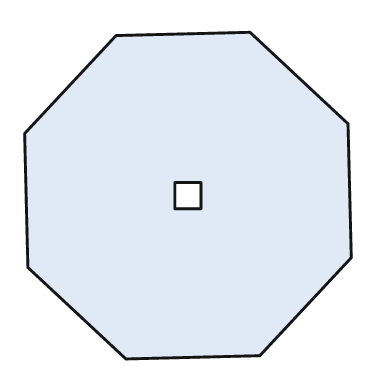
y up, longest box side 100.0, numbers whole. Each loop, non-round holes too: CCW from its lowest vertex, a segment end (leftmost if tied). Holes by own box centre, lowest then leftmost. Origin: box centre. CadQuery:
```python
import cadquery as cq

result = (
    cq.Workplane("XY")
    .moveTo(-19.0, -50.0)
    .lineTo(22.0, -49.0)
    .lineTo(50.0, -19.0)
    .lineTo(49.0, 22.0)
    .lineTo(19.0, 50.0)
    .lineTo(-22.0, 49.0)
    .lineTo(-50.0, 19.0)
    .lineTo(-49.0, -22.0)
    .close()
    .moveTo(-4.0, -4.0)
    .lineTo(4.0, -4.0)
    .lineTo(4.0, 4.0)
    .lineTo(-4.0, 4.0)
    .close()
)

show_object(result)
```